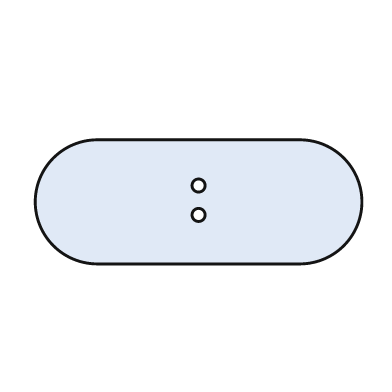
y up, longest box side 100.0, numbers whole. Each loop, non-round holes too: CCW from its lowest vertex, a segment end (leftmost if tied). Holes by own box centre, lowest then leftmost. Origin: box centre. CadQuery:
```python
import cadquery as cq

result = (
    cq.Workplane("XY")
    .moveTo(-31.0, -19.0)
    .lineTo(31.0, -19.0)
    .threePointArc((50.0, 0.0), (31.0, 19.0))
    .lineTo(-31.0, 19.0)
    .threePointArc((-50.0, 0.0), (-31.0, -19.0))
    .close()
    .moveTo(0.0, -4.0)
    .circle(2.0)
    .moveTo(0.0, 5.0)
    .circle(2.0)
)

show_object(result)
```